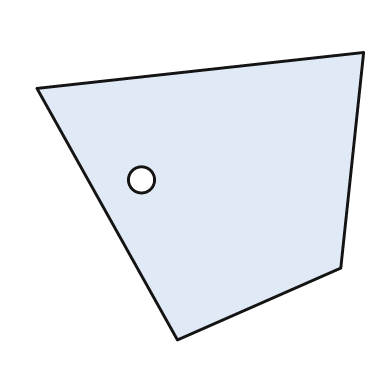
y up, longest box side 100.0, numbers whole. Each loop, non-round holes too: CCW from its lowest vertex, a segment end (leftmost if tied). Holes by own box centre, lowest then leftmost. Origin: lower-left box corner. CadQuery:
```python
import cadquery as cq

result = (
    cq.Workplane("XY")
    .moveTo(43.0, 0.0)
    .lineTo(93.0, 22.0)
    .lineTo(100.0, 88.0)
    .lineTo(0.0, 77.0)
    .close()
    .moveTo(32.0, 49.0)
    .circle(4.0)
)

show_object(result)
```